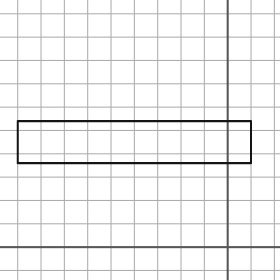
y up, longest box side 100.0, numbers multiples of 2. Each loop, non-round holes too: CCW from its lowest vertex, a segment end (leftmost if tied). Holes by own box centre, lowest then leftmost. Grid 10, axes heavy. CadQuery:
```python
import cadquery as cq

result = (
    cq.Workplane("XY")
    .moveTo(-90.0, 36.0)
    .lineTo(10.0, 36.0)
    .lineTo(10.0, 54.0)
    .lineTo(-90.0, 54.0)
    .close()
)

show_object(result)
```